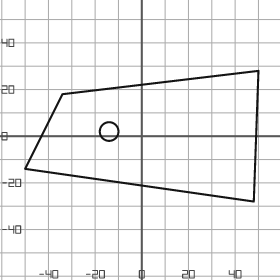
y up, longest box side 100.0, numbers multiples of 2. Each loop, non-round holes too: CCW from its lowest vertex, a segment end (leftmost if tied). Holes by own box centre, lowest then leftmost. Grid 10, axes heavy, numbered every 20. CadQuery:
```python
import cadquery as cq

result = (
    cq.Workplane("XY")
    .moveTo(48.0, -28.0)
    .lineTo(50.0, 28.0)
    .lineTo(-34.0, 18.0)
    .lineTo(-50.0, -14.0)
    .close()
    .moveTo(-14.0, 2.0)
    .circle(4.0)
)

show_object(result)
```